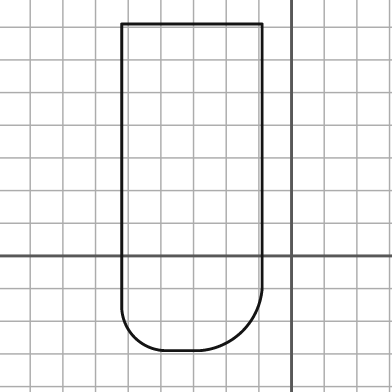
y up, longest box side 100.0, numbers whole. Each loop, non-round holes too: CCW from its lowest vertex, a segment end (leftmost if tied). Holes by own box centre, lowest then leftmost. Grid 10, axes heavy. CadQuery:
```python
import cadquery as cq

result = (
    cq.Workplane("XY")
    .moveTo(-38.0, -29.0)
    .lineTo(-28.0, -29.0)
    .threePointArc((-15.0, -23.0), (-9.0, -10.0))
    .lineTo(-9.0, 71.0)
    .lineTo(-52.0, 71.0)
    .lineTo(-52.0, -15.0)
    .threePointArc((-48.0, -25.0), (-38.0, -29.0))
    .close()
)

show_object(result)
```